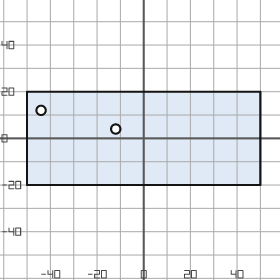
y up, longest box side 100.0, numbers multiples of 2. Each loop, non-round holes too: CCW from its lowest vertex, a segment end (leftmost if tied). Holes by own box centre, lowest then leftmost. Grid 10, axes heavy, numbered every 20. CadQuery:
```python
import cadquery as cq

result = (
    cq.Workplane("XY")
    .moveTo(-50.0, -20.0)
    .lineTo(50.0, -20.0)
    .lineTo(50.0, 20.0)
    .lineTo(-50.0, 20.0)
    .close()
    .moveTo(-12.0, 4.0)
    .circle(2.0)
    .moveTo(-44.0, 12.0)
    .circle(2.0)
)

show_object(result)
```